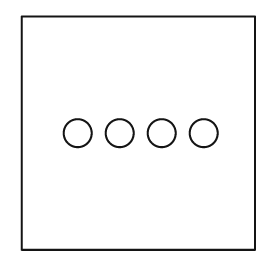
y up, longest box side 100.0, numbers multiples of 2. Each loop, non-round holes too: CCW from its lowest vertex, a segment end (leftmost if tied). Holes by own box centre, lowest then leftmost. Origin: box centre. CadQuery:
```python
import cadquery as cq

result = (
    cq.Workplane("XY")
    .moveTo(-50.0, -50.0)
    .lineTo(50.0, -50.0)
    .lineTo(50.0, 50.0)
    .lineTo(-50.0, 50.0)
    .close()
    .moveTo(-26.0, 0.0)
    .circle(6.0)
    .moveTo(-8.0, 0.0)
    .circle(6.0)
    .moveTo(10.0, 0.0)
    .circle(6.0)
    .moveTo(28.0, 0.0)
    .circle(6.0)
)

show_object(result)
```